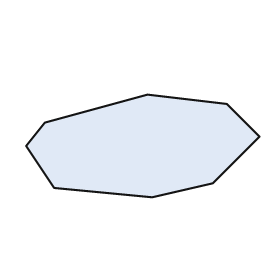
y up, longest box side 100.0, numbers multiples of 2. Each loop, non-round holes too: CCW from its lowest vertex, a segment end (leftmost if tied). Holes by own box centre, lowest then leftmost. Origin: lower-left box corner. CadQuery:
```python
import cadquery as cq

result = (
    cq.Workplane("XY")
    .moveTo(54.0, 0.0)
    .lineTo(80.0, 6.0)
    .lineTo(100.0, 26.0)
    .lineTo(86.0, 40.0)
    .lineTo(52.0, 44.0)
    .lineTo(8.0, 32.0)
    .lineTo(0.0, 22.0)
    .lineTo(12.0, 4.0)
    .close()
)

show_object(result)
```